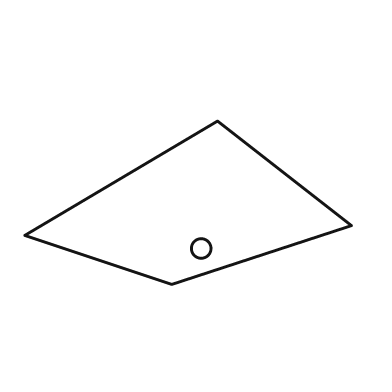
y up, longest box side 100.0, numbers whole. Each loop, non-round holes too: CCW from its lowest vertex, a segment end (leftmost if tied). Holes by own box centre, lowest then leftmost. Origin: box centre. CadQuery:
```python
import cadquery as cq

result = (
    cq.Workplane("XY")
    .moveTo(-5.0, -25.0)
    .lineTo(50.0, -7.0)
    .lineTo(9.0, 25.0)
    .lineTo(-50.0, -10.0)
    .close()
    .moveTo(4.0, -14.0)
    .circle(3.0)
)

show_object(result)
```